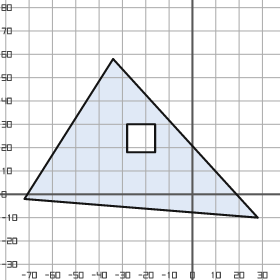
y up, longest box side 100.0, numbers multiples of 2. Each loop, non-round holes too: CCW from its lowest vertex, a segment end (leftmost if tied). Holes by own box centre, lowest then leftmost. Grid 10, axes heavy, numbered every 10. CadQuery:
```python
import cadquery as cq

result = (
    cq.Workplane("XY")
    .moveTo(28.0, -10.0)
    .lineTo(-34.0, 58.0)
    .lineTo(-72.0, -2.0)
    .close()
    .moveTo(-28.0, 18.0)
    .lineTo(-16.0, 18.0)
    .lineTo(-16.0, 30.0)
    .lineTo(-28.0, 30.0)
    .close()
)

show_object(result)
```